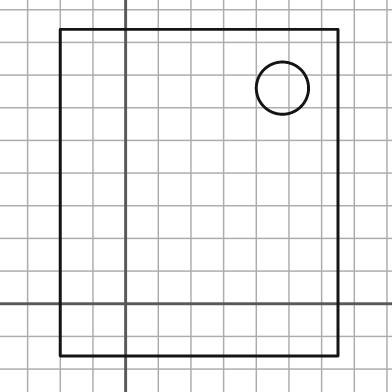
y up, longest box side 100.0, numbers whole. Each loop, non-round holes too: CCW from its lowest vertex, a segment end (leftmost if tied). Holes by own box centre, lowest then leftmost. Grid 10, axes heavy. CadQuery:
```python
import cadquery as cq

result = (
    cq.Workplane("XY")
    .moveTo(-20.0, -16.0)
    .lineTo(65.0, -16.0)
    .lineTo(65.0, 84.0)
    .lineTo(-20.0, 84.0)
    .close()
    .moveTo(48.0, 66.0)
    .circle(8.0)
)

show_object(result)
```